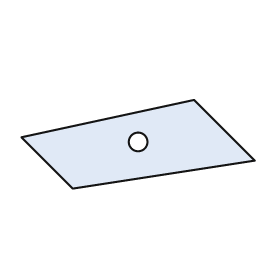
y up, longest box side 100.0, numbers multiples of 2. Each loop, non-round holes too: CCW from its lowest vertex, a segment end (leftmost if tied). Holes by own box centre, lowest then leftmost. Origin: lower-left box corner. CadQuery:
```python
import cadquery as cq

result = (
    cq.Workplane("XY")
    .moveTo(22.0, 0.0)
    .lineTo(100.0, 12.0)
    .lineTo(74.0, 38.0)
    .lineTo(0.0, 22.0)
    .close()
    .moveTo(50.0, 20.0)
    .circle(4.0)
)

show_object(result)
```